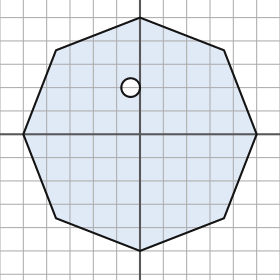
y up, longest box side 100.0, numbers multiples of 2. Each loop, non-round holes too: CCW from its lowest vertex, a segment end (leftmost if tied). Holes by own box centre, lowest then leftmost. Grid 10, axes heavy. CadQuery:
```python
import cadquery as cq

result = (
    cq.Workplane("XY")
    .moveTo(0.0, -50.0)
    .lineTo(36.0, -36.0)
    .lineTo(50.0, 0.0)
    .lineTo(36.0, 36.0)
    .lineTo(0.0, 50.0)
    .lineTo(-36.0, 36.0)
    .lineTo(-50.0, 0.0)
    .lineTo(-36.0, -36.0)
    .close()
    .moveTo(-4.0, 20.0)
    .circle(4.0)
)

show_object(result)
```